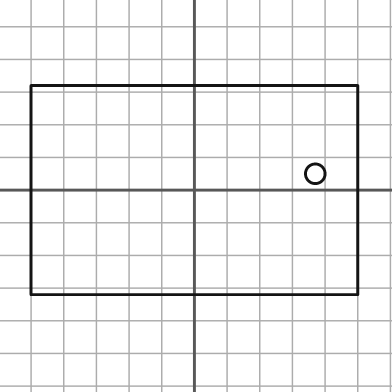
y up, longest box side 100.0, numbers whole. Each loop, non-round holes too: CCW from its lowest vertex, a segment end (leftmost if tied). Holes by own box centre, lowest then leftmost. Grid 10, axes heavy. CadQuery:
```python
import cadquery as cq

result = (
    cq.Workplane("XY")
    .moveTo(-50.0, -32.0)
    .lineTo(50.0, -32.0)
    .lineTo(50.0, 32.0)
    .lineTo(-50.0, 32.0)
    .close()
    .moveTo(37.0, 5.0)
    .circle(3.0)
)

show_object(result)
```